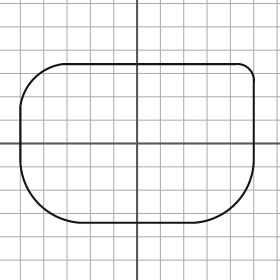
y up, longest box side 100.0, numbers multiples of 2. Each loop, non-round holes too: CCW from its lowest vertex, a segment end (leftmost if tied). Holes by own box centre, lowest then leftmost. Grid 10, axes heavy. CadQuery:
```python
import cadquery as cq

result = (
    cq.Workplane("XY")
    .moveTo(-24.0, -34.0)
    .lineTo(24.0, -34.0)
    .threePointArc((42.0, -26.0), (50.0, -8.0))
    .lineTo(50.0, 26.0)
    .threePointArc((48.0, 32.0), (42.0, 34.0))
    .lineTo(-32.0, 34.0)
    .threePointArc((-44.0, 28.0), (-50.0, 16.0))
    .lineTo(-50.0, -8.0)
    .threePointArc((-42.0, -26.0), (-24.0, -34.0))
    .close()
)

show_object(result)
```